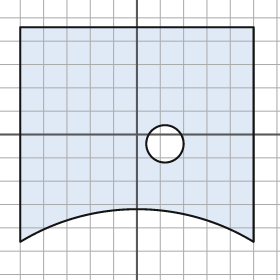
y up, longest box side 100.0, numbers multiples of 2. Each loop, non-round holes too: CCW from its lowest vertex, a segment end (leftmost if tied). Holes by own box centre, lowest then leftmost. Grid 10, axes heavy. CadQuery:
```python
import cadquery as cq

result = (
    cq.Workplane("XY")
    .moveTo(-50.0, -46.0)
    .threePointArc((0.0, -32.0), (50.0, -46.0))
    .lineTo(50.0, 46.0)
    .lineTo(-50.0, 46.0)
    .close()
    .moveTo(12.0, -4.0)
    .circle(8.0)
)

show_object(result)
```